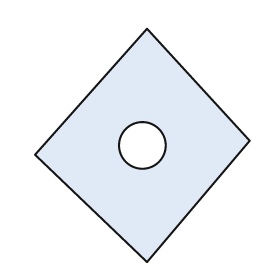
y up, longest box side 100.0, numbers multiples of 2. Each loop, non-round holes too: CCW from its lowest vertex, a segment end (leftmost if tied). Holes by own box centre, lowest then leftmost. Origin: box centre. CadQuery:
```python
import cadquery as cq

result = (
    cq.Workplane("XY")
    .moveTo(2.0, -50.0)
    .lineTo(46.0, 2.0)
    .lineTo(2.0, 50.0)
    .lineTo(-46.0, -4.0)
    .close()
    .moveTo(0.0, 0.0)
    .circle(10.0)
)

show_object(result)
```